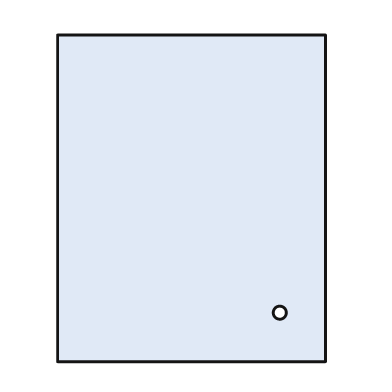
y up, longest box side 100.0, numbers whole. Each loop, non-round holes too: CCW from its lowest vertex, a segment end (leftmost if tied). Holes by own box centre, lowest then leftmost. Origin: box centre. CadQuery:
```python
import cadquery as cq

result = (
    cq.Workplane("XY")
    .moveTo(-41.0, -50.0)
    .lineTo(41.0, -50.0)
    .lineTo(41.0, 50.0)
    .lineTo(-41.0, 50.0)
    .close()
    .moveTo(27.0, -35.0)
    .circle(2.0)
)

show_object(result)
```